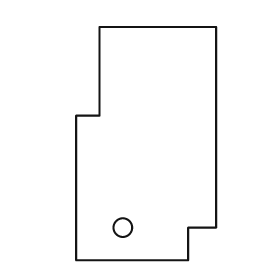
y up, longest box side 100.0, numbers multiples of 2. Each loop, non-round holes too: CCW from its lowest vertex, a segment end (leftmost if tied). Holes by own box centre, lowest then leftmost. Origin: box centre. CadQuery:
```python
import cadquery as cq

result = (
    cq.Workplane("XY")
    .moveTo(-30.0, -50.0)
    .lineTo(18.0, -50.0)
    .lineTo(18.0, -36.0)
    .lineTo(30.0, -36.0)
    .lineTo(30.0, 50.0)
    .lineTo(-20.0, 50.0)
    .lineTo(-20.0, 12.0)
    .lineTo(-30.0, 12.0)
    .close()
    .moveTo(-10.0, -36.0)
    .circle(4.0)
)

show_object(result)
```